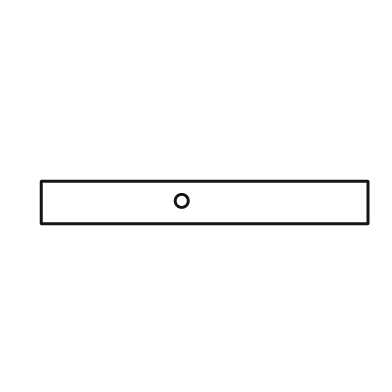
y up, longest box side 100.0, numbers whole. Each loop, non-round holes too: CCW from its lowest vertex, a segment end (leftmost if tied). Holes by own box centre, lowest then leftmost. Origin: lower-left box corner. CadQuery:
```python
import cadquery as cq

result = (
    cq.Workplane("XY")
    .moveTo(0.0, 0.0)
    .lineTo(100.0, 0.0)
    .lineTo(100.0, 13.0)
    .lineTo(0.0, 13.0)
    .close()
    .moveTo(43.0, 7.0)
    .circle(2.0)
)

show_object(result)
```